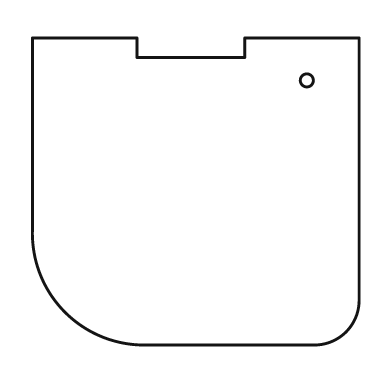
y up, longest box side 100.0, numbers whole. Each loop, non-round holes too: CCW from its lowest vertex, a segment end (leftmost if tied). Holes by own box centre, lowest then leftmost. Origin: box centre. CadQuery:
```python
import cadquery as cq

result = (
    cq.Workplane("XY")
    .moveTo(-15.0, -47.0)
    .lineTo(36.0, -47.0)
    .threePointArc((46.0, -43.0), (50.0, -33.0))
    .lineTo(50.0, 47.0)
    .lineTo(15.0, 47.0)
    .lineTo(15.0, 41.0)
    .lineTo(-18.0, 41.0)
    .lineTo(-18.0, 47.0)
    .lineTo(-50.0, 47.0)
    .lineTo(-50.0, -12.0)
    .threePointArc((-40.0, -37.0), (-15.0, -47.0))
    .close()
    .moveTo(34.0, 34.0)
    .circle(2.0)
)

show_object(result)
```